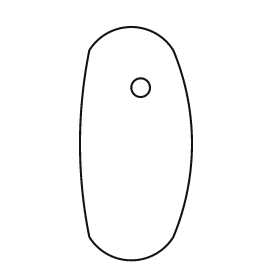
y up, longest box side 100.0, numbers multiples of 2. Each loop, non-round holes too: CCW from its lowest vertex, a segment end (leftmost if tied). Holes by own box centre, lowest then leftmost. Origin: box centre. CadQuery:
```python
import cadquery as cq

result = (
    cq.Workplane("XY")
    .moveTo(-20.0, -40.0)
    .threePointArc((-2.0, -50.0), (16.0, -40.0))
    .threePointArc((24.0, 0.0), (16.0, 40.0))
    .threePointArc((-2.0, 50.0), (-20.0, 40.0))
    .threePointArc((-24.0, 0.0), (-20.0, -40.0))
    .close()
    .moveTo(2.0, 24.0)
    .circle(4.0)
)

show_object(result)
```